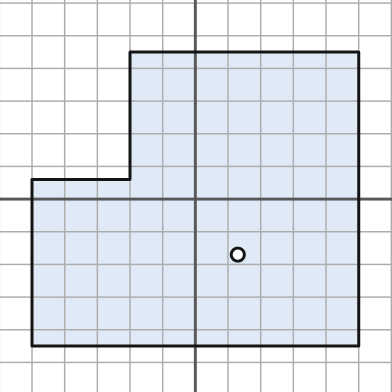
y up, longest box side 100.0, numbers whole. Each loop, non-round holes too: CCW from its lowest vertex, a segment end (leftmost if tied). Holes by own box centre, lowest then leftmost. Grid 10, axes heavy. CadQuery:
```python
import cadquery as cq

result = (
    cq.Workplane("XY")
    .moveTo(-50.0, -45.0)
    .lineTo(50.0, -45.0)
    .lineTo(50.0, 45.0)
    .lineTo(-20.0, 45.0)
    .lineTo(-20.0, 6.0)
    .lineTo(-50.0, 6.0)
    .close()
    .moveTo(13.0, -17.0)
    .circle(2.0)
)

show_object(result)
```